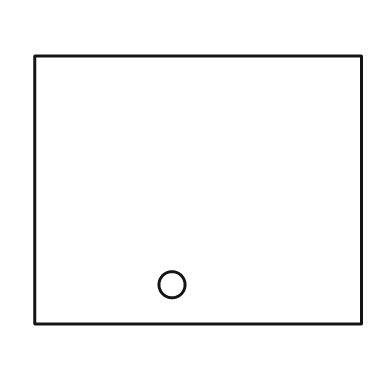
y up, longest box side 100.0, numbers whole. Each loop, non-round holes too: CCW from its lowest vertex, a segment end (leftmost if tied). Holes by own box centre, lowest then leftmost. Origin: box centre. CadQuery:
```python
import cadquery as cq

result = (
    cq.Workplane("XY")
    .moveTo(-50.0, -41.0)
    .lineTo(50.0, -41.0)
    .lineTo(50.0, 41.0)
    .lineTo(-50.0, 41.0)
    .close()
    .moveTo(-8.0, -29.0)
    .circle(4.0)
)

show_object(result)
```